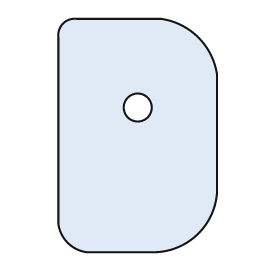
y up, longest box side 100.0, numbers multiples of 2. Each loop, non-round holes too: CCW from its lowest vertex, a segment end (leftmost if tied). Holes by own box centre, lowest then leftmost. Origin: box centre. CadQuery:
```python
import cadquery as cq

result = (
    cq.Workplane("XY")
    .moveTo(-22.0, -50.0)
    .lineTo(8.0, -50.0)
    .threePointArc((26.0, -42.0), (34.0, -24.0))
    .lineTo(34.0, 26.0)
    .threePointArc((26.0, 42.0), (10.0, 50.0))
    .lineTo(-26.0, 50.0)
    .threePointArc((-32.0, 48.0), (-34.0, 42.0))
    .lineTo(-34.0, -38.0)
    .threePointArc((-30.0, -46.0), (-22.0, -50.0))
    .close()
    .moveTo(0.0, 12.0)
    .circle(6.0)
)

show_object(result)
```